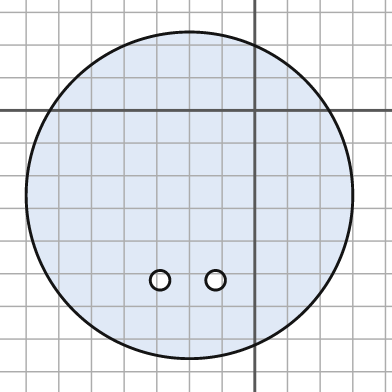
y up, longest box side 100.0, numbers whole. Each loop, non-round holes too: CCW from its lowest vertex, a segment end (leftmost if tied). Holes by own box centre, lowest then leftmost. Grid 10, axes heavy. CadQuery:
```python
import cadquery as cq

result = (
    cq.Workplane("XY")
    .moveTo(-20.0, -26.0)
    .circle(50.0)
    .moveTo(-29.0, -52.0)
    .circle(3.0)
    .moveTo(-12.0, -52.0)
    .circle(3.0)
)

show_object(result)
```